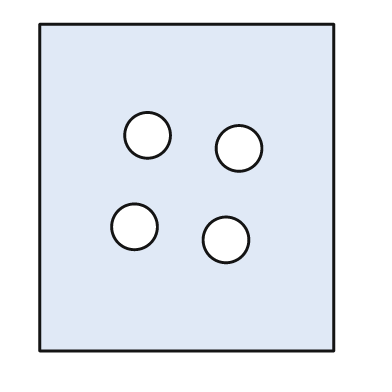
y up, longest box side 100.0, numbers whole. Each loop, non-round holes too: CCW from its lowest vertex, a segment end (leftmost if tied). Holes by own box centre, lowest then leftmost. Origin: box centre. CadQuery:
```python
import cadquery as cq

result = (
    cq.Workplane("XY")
    .moveTo(-45.0, -50.0)
    .lineTo(45.0, -50.0)
    .lineTo(45.0, 50.0)
    .lineTo(-45.0, 50.0)
    .close()
    .moveTo(12.0, -16.0)
    .circle(7.0)
    .moveTo(-16.0, -12.0)
    .circle(7.0)
    .moveTo(16.0, 12.0)
    .circle(7.0)
    .moveTo(-12.0, 16.0)
    .circle(7.0)
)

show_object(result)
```